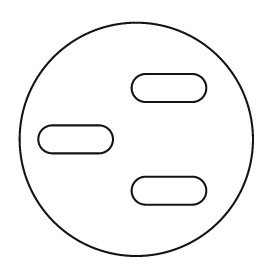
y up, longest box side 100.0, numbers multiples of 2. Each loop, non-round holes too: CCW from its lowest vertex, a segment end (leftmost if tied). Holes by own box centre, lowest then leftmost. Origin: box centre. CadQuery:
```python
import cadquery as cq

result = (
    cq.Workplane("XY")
    .moveTo(0.0, 0.0)
    .circle(50.0)
    .moveTo(4.0, -28.0)
    .lineTo(24.0, -28.0)
    .threePointArc((30.0, -22.0), (24.0, -16.0))
    .lineTo(4.0, -16.0)
    .threePointArc((-2.0, -22.0), (4.0, -28.0))
    .close()
    .moveTo(-36.0, -6.0)
    .lineTo(-16.0, -6.0)
    .threePointArc((-10.0, 0.0), (-16.0, 6.0))
    .lineTo(-36.0, 6.0)
    .threePointArc((-42.0, 0.0), (-36.0, -6.0))
    .close()
    .moveTo(4.0, 16.0)
    .lineTo(24.0, 16.0)
    .threePointArc((30.0, 22.0), (24.0, 28.0))
    .lineTo(4.0, 28.0)
    .threePointArc((-2.0, 22.0), (4.0, 16.0))
    .close()
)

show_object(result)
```